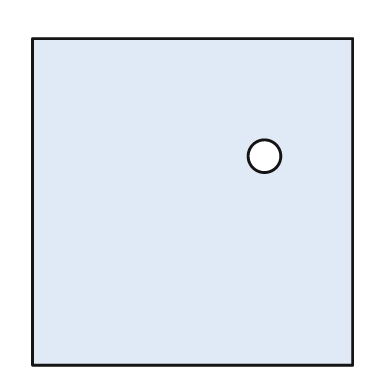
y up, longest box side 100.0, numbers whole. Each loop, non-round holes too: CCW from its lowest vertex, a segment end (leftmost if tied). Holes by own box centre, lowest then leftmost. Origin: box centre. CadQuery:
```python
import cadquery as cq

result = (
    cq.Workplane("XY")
    .moveTo(-49.0, -50.0)
    .lineTo(49.0, -50.0)
    .lineTo(49.0, 50.0)
    .lineTo(-49.0, 50.0)
    .close()
    .moveTo(22.0, 14.0)
    .circle(5.0)
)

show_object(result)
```